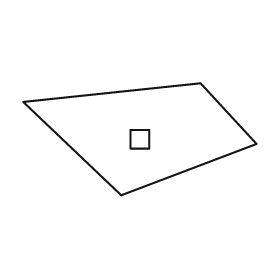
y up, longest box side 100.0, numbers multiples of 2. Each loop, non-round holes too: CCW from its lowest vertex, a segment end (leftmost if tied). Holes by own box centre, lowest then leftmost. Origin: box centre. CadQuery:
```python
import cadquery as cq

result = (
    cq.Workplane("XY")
    .moveTo(-8.0, -24.0)
    .lineTo(50.0, -2.0)
    .lineTo(26.0, 24.0)
    .lineTo(-50.0, 16.0)
    .close()
    .moveTo(-4.0, -4.0)
    .lineTo(4.0, -4.0)
    .lineTo(4.0, 4.0)
    .lineTo(-4.0, 4.0)
    .close()
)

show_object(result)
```